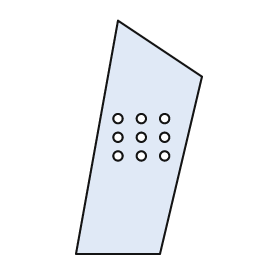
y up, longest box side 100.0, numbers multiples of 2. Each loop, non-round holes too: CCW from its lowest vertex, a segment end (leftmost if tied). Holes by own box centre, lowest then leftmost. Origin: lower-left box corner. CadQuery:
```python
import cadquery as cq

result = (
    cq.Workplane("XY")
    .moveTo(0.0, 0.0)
    .lineTo(36.0, 0.0)
    .lineTo(54.0, 76.0)
    .lineTo(18.0, 100.0)
    .close()
    .moveTo(18.0, 42.0)
    .circle(2.0)
    .moveTo(28.0, 42.0)
    .circle(2.0)
    .moveTo(38.0, 42.0)
    .circle(2.0)
    .moveTo(18.0, 50.0)
    .circle(2.0)
    .moveTo(28.0, 50.0)
    .circle(2.0)
    .moveTo(38.0, 50.0)
    .circle(2.0)
    .moveTo(18.0, 58.0)
    .circle(2.0)
    .moveTo(28.0, 58.0)
    .circle(2.0)
    .moveTo(38.0, 58.0)
    .circle(2.0)
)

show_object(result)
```